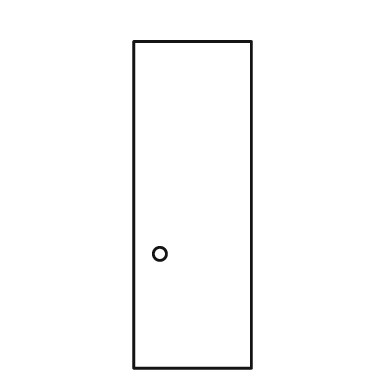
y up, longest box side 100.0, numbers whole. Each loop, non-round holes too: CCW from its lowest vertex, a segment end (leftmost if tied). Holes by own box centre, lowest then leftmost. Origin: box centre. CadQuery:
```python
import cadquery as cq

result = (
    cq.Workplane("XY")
    .moveTo(-18.0, -50.0)
    .lineTo(18.0, -50.0)
    .lineTo(18.0, 50.0)
    .lineTo(-18.0, 50.0)
    .close()
    .moveTo(-10.0, -15.0)
    .circle(2.0)
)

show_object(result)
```